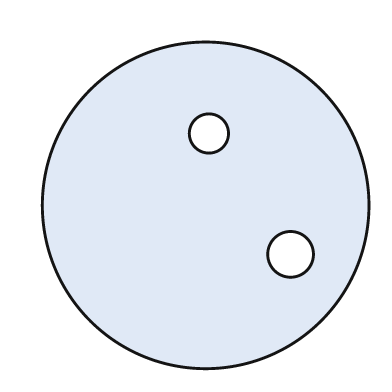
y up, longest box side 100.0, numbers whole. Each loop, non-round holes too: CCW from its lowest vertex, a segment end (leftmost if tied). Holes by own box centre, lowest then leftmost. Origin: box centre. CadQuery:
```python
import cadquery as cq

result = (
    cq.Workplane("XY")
    .moveTo(0.0, 0.0)
    .circle(50.0)
    .moveTo(26.0, -15.0)
    .circle(7.0)
    .moveTo(1.0, 22.0)
    .circle(6.0)
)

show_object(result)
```